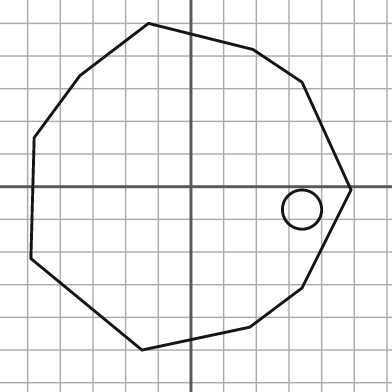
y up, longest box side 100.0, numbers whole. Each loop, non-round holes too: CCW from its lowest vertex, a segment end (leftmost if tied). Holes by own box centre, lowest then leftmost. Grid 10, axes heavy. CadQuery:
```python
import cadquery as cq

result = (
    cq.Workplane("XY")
    .moveTo(-15.0, -50.0)
    .lineTo(18.0, -43.0)
    .lineTo(34.0, -31.0)
    .lineTo(49.0, -1.0)
    .lineTo(34.0, 32.0)
    .lineTo(19.0, 42.0)
    .lineTo(-13.0, 50.0)
    .lineTo(-34.0, 34.0)
    .lineTo(-48.0, 15.0)
    .lineTo(-49.0, -22.0)
    .close()
    .moveTo(34.0, -7.0)
    .circle(6.0)
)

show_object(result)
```